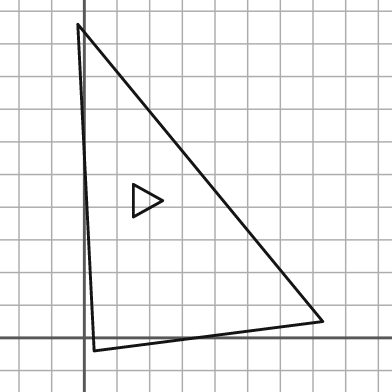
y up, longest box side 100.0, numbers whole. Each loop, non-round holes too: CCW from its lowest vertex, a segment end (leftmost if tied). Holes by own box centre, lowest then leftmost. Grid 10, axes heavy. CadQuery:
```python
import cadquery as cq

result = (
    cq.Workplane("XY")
    .moveTo(3.0, -4.0)
    .lineTo(73.0, 5.0)
    .lineTo(-2.0, 96.0)
    .close()
    .moveTo(15.0, 37.0)
    .lineTo(24.0, 42.0)
    .lineTo(15.0, 47.0)
    .close()
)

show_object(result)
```